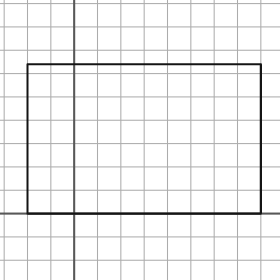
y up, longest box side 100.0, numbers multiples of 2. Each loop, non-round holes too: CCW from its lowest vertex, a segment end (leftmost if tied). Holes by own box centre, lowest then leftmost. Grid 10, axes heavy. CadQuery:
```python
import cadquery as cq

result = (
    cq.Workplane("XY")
    .moveTo(-20.0, 0.0)
    .lineTo(80.0, 0.0)
    .lineTo(80.0, 64.0)
    .lineTo(-20.0, 64.0)
    .close()
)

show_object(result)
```